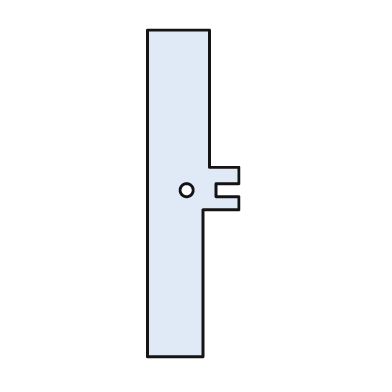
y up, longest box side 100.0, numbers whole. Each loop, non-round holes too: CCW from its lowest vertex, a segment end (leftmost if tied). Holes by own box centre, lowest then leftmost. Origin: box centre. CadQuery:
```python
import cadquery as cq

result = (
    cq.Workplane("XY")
    .moveTo(-14.0, -50.0)
    .lineTo(3.0, -50.0)
    .lineTo(3.0, -5.0)
    .lineTo(14.0, -5.0)
    .lineTo(14.0, -1.0)
    .lineTo(7.0, -1.0)
    .lineTo(7.0, 3.0)
    .lineTo(14.0, 3.0)
    .lineTo(14.0, 8.0)
    .lineTo(5.0, 8.0)
    .lineTo(5.0, 50.0)
    .lineTo(-14.0, 50.0)
    .close()
    .moveTo(-2.0, 1.0)
    .circle(2.0)
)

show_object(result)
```